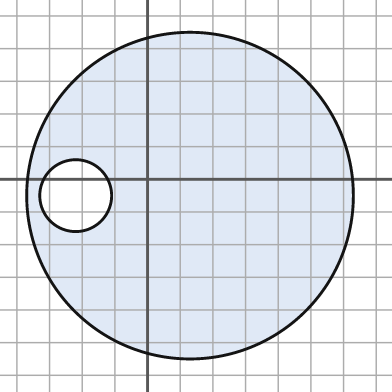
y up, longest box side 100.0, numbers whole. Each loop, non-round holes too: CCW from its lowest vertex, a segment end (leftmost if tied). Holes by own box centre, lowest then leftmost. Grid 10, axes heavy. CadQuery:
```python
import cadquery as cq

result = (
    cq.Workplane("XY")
    .moveTo(13.0, -5.0)
    .circle(50.0)
    .moveTo(-22.0, -5.0)
    .circle(11.0)
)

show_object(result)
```